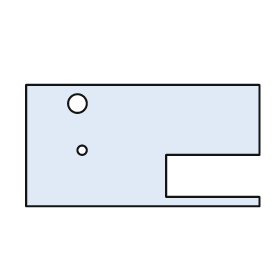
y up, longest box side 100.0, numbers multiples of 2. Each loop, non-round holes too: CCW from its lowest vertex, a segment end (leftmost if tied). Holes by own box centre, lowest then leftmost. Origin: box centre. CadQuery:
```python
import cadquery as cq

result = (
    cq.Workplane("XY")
    .moveTo(-50.0, -26.0)
    .lineTo(50.0, -26.0)
    .lineTo(50.0, -22.0)
    .lineTo(10.0, -22.0)
    .lineTo(10.0, -4.0)
    .lineTo(50.0, -4.0)
    .lineTo(50.0, 26.0)
    .lineTo(-50.0, 26.0)
    .close()
    .moveTo(-26.0, -2.0)
    .circle(2.0)
    .moveTo(-28.0, 18.0)
    .circle(4.0)
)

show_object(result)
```